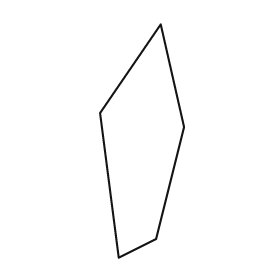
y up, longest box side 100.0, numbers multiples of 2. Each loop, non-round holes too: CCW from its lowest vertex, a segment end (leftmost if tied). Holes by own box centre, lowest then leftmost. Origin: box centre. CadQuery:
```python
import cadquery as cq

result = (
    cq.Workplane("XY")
    .moveTo(-10.0, -50.0)
    .lineTo(6.0, -42.0)
    .lineTo(18.0, 6.0)
    .lineTo(8.0, 50.0)
    .lineTo(-18.0, 12.0)
    .close()
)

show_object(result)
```